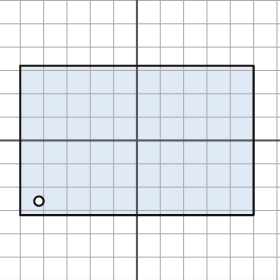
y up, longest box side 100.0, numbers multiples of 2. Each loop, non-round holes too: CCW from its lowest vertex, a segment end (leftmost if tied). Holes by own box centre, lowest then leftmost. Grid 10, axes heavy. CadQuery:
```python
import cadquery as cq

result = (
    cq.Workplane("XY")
    .moveTo(-50.0, -32.0)
    .lineTo(50.0, -32.0)
    .lineTo(50.0, 32.0)
    .lineTo(-50.0, 32.0)
    .close()
    .moveTo(-42.0, -26.0)
    .circle(2.0)
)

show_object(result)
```